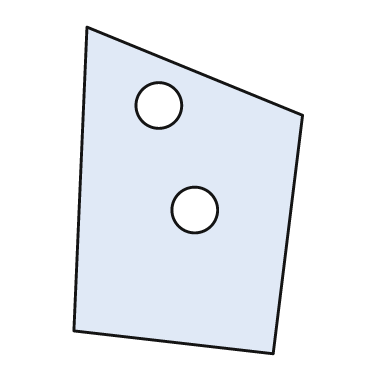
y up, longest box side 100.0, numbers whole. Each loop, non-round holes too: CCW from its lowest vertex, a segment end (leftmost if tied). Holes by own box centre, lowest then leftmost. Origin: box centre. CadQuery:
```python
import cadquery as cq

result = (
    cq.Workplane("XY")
    .moveTo(26.0, -50.0)
    .lineTo(35.0, 23.0)
    .lineTo(-31.0, 50.0)
    .lineTo(-35.0, -43.0)
    .close()
    .moveTo(2.0, -6.0)
    .circle(7.0)
    .moveTo(-9.0, 26.0)
    .circle(7.0)
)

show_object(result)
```